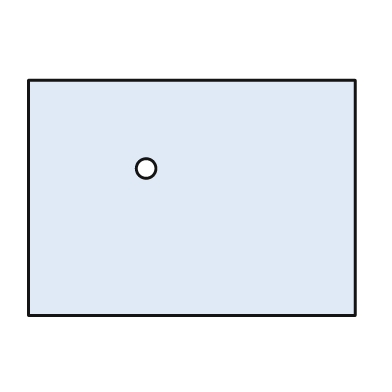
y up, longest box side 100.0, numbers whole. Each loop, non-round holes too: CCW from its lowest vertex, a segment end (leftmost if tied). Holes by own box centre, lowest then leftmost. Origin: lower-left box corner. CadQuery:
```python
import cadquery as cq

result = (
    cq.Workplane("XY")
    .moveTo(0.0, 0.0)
    .lineTo(100.0, 0.0)
    .lineTo(100.0, 72.0)
    .lineTo(0.0, 72.0)
    .close()
    .moveTo(36.0, 45.0)
    .circle(3.0)
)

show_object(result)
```